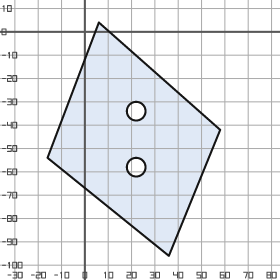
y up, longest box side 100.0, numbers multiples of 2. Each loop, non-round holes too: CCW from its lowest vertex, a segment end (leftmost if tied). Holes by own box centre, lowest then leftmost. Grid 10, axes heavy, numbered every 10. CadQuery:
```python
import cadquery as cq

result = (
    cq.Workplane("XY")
    .moveTo(36.0, -96.0)
    .lineTo(58.0, -42.0)
    .lineTo(6.0, 4.0)
    .lineTo(-16.0, -54.0)
    .close()
    .moveTo(22.0, -58.0)
    .circle(4.0)
    .moveTo(22.0, -34.0)
    .circle(4.0)
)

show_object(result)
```